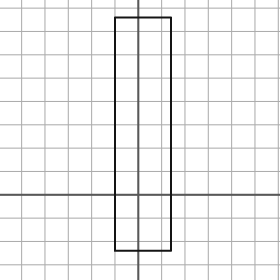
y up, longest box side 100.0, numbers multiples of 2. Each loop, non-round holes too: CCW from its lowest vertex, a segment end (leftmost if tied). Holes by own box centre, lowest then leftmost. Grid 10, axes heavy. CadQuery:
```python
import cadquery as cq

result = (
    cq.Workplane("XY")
    .moveTo(-10.0, -24.0)
    .lineTo(14.0, -24.0)
    .lineTo(14.0, 76.0)
    .lineTo(-10.0, 76.0)
    .close()
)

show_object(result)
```